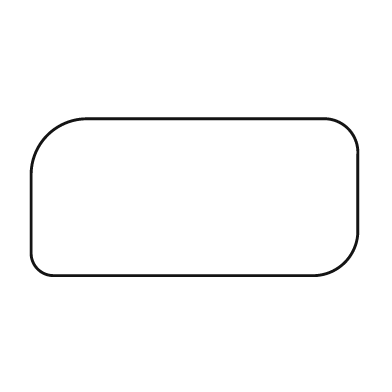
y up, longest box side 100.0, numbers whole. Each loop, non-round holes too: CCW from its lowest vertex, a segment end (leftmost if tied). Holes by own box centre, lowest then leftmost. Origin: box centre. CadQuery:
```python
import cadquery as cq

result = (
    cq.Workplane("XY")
    .moveTo(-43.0, -24.0)
    .lineTo(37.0, -24.0)
    .threePointArc((46.0, -20.0), (50.0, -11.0))
    .lineTo(50.0, 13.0)
    .threePointArc((47.0, 21.0), (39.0, 24.0))
    .lineTo(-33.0, 24.0)
    .threePointArc((-45.0, 19.0), (-50.0, 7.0))
    .lineTo(-50.0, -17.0)
    .threePointArc((-48.0, -22.0), (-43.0, -24.0))
    .close()
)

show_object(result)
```